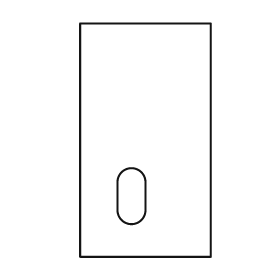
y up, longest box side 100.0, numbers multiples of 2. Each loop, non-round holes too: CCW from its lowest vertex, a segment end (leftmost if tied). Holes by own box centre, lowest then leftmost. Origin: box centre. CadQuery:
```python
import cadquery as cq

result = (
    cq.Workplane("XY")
    .moveTo(-28.0, -50.0)
    .lineTo(28.0, -50.0)
    .lineTo(28.0, 50.0)
    .lineTo(-28.0, 50.0)
    .close()
    .moveTo(-12.0, -30.0)
    .threePointArc((-6.0, -36.0), (0.0, -30.0))
    .lineTo(0.0, -18.0)
    .threePointArc((-6.0, -12.0), (-12.0, -18.0))
    .close()
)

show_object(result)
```